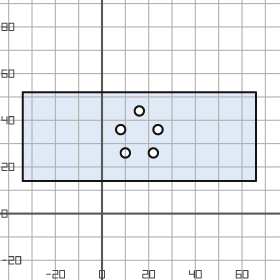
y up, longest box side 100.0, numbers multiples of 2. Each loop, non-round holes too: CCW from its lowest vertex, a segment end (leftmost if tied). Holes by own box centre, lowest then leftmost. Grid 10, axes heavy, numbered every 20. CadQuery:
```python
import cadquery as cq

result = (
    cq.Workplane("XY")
    .moveTo(-34.0, 14.0)
    .lineTo(66.0, 14.0)
    .lineTo(66.0, 52.0)
    .lineTo(-34.0, 52.0)
    .close()
    .moveTo(10.0, 26.0)
    .circle(2.0)
    .moveTo(22.0, 26.0)
    .circle(2.0)
    .moveTo(8.0, 36.0)
    .circle(2.0)
    .moveTo(24.0, 36.0)
    .circle(2.0)
    .moveTo(16.0, 44.0)
    .circle(2.0)
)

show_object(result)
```